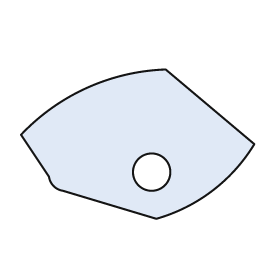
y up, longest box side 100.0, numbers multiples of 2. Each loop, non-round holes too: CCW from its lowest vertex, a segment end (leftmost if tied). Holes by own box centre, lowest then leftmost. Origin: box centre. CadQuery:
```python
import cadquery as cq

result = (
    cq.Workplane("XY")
    .moveTo(8.0, -32.0)
    .threePointArc((32.0, -20.0), (50.0, 0.0))
    .lineTo(12.0, 32.0)
    .threePointArc((-22.0, 24.0), (-50.0, 4.0))
    .lineTo(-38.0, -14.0)
    .threePointArc((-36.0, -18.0), (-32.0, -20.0))
    .close()
    .moveTo(6.0, -12.0)
    .circle(8.0)
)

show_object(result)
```